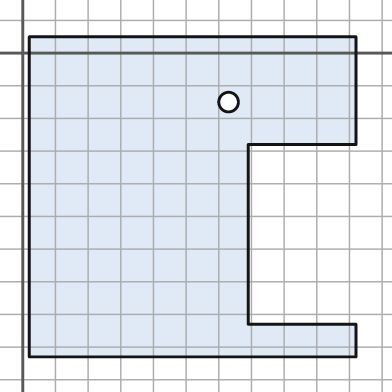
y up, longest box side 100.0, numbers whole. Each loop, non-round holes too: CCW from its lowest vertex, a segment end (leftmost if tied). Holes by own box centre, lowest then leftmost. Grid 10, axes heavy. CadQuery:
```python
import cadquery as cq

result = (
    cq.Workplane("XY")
    .moveTo(2.0, -93.0)
    .lineTo(102.0, -93.0)
    .lineTo(102.0, -83.0)
    .lineTo(69.0, -83.0)
    .lineTo(69.0, -28.0)
    .lineTo(102.0, -28.0)
    .lineTo(102.0, 5.0)
    .lineTo(2.0, 5.0)
    .close()
    .moveTo(63.0, -15.0)
    .circle(3.0)
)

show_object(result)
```